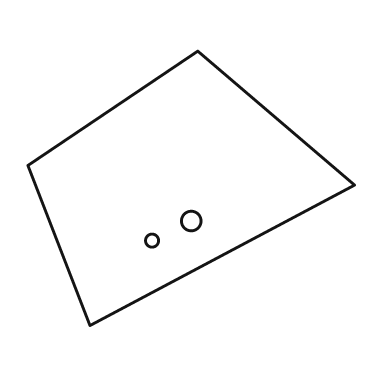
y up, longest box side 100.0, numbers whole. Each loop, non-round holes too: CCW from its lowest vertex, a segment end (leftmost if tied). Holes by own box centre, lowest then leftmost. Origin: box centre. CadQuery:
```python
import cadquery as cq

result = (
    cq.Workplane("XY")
    .moveTo(-31.0, -42.0)
    .lineTo(50.0, 1.0)
    .lineTo(2.0, 42.0)
    .lineTo(-50.0, 7.0)
    .close()
    .moveTo(-12.0, -16.0)
    .circle(2.0)
    .moveTo(0.0, -10.0)
    .circle(3.0)
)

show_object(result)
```